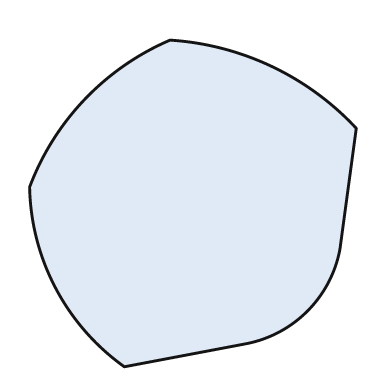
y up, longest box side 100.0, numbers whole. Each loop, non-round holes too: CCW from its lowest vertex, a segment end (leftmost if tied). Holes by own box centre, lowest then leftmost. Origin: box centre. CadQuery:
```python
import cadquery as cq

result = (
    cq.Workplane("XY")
    .moveTo(-21.0, -50.0)
    .lineTo(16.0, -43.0)
    .threePointArc((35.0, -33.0), (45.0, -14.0))
    .lineTo(50.0, 23.0)
    .threePointArc((24.0, 42.0), (-7.0, 50.0))
    .threePointArc((-33.0, 32.0), (-50.0, 5.0))
    .threePointArc((-42.0, -26.0), (-21.0, -50.0))
    .close()
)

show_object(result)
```